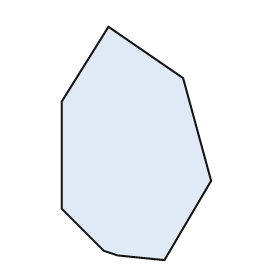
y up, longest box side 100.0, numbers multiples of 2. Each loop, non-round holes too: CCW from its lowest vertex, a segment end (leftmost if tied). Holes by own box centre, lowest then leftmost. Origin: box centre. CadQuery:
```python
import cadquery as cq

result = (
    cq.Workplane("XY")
    .moveTo(12.0, -50.0)
    .lineTo(32.0, -16.0)
    .lineTo(20.0, 28.0)
    .lineTo(-12.0, 50.0)
    .lineTo(-32.0, 18.0)
    .lineTo(-32.0, -28.0)
    .lineTo(-14.0, -46.0)
    .lineTo(-8.0, -48.0)
    .close()
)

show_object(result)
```